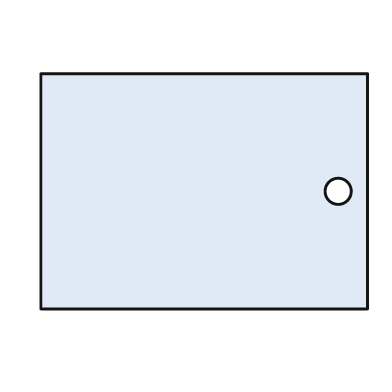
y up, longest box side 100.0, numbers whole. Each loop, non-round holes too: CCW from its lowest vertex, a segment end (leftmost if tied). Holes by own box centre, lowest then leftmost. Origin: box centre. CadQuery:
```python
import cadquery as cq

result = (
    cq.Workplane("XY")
    .moveTo(-50.0, -36.0)
    .lineTo(50.0, -36.0)
    .lineTo(50.0, 36.0)
    .lineTo(-50.0, 36.0)
    .close()
    .moveTo(41.0, 0.0)
    .circle(4.0)
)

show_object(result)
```